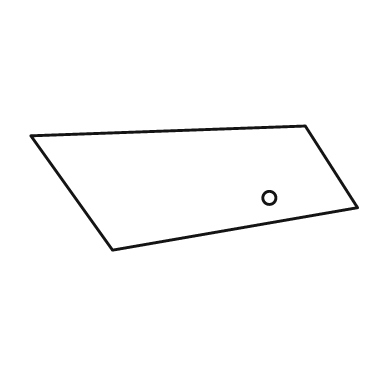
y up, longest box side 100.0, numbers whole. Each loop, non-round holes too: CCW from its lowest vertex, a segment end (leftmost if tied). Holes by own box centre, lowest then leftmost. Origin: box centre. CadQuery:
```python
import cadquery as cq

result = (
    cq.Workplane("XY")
    .moveTo(-25.0, -19.0)
    .lineTo(50.0, -6.0)
    .lineTo(34.0, 19.0)
    .lineTo(-50.0, 16.0)
    .close()
    .moveTo(23.0, -3.0)
    .circle(2.0)
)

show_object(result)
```